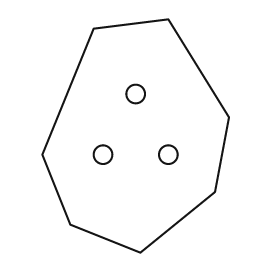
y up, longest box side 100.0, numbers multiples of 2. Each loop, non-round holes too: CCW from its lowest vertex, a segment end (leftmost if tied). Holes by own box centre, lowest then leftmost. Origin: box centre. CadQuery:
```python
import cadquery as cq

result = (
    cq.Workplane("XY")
    .moveTo(2.0, -50.0)
    .lineTo(34.0, -24.0)
    .lineTo(40.0, 8.0)
    .lineTo(14.0, 50.0)
    .lineTo(-18.0, 46.0)
    .lineTo(-40.0, -8.0)
    .lineTo(-28.0, -38.0)
    .close()
    .moveTo(-14.0, -8.0)
    .circle(4.0)
    .moveTo(14.0, -8.0)
    .circle(4.0)
    .moveTo(0.0, 18.0)
    .circle(4.0)
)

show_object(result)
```